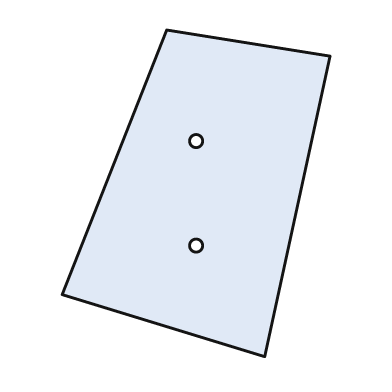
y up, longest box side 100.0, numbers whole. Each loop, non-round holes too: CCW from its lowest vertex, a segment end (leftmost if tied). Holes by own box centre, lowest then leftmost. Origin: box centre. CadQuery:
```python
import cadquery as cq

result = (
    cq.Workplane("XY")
    .moveTo(21.0, -50.0)
    .lineTo(41.0, 42.0)
    .lineTo(-9.0, 50.0)
    .lineTo(-41.0, -31.0)
    .close()
    .moveTo(0.0, -16.0)
    .circle(2.0)
    .moveTo(0.0, 16.0)
    .circle(2.0)
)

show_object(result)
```